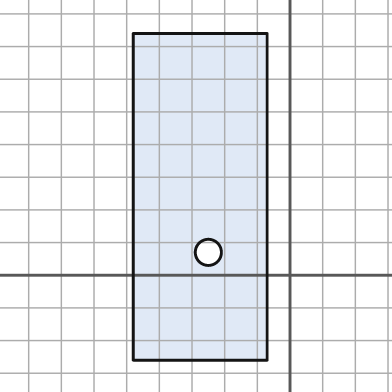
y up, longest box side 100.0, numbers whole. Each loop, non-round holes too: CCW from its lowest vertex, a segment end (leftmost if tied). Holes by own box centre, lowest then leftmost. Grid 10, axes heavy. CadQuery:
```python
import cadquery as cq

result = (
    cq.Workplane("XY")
    .moveTo(-48.0, -26.0)
    .lineTo(-7.0, -26.0)
    .lineTo(-7.0, 74.0)
    .lineTo(-48.0, 74.0)
    .close()
    .moveTo(-25.0, 7.0)
    .circle(4.0)
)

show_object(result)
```